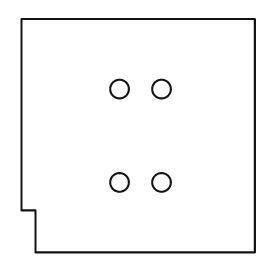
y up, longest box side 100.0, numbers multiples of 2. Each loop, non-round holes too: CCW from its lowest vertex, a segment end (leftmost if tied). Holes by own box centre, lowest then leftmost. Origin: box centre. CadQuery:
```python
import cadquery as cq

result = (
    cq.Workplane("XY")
    .moveTo(-44.0, -50.0)
    .lineTo(50.0, -50.0)
    .lineTo(50.0, 50.0)
    .lineTo(-50.0, 50.0)
    .lineTo(-50.0, -32.0)
    .lineTo(-44.0, -32.0)
    .close()
    .moveTo(-8.0, -20.0)
    .circle(4.0)
    .moveTo(10.0, -20.0)
    .circle(4.0)
    .moveTo(-8.0, 20.0)
    .circle(4.0)
    .moveTo(10.0, 20.0)
    .circle(4.0)
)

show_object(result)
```